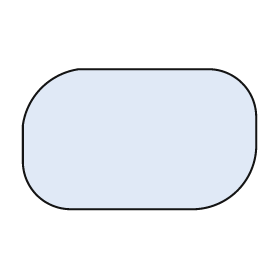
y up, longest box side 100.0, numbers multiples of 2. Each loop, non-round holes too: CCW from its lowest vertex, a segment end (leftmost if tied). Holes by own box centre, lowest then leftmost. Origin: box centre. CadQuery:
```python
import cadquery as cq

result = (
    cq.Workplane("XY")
    .moveTo(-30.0, -30.0)
    .lineTo(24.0, -30.0)
    .threePointArc((42.0, -22.0), (50.0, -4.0))
    .lineTo(50.0, 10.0)
    .threePointArc((44.0, 24.0), (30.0, 30.0))
    .lineTo(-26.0, 30.0)
    .threePointArc((-42.0, 22.0), (-50.0, 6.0))
    .lineTo(-50.0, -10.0)
    .threePointArc((-44.0, -24.0), (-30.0, -30.0))
    .close()
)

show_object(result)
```